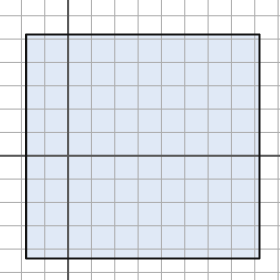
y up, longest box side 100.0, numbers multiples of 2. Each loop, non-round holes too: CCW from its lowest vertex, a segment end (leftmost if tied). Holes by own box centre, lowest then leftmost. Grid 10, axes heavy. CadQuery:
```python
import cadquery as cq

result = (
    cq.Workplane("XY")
    .moveTo(-18.0, -44.0)
    .lineTo(82.0, -44.0)
    .lineTo(82.0, 52.0)
    .lineTo(-18.0, 52.0)
    .close()
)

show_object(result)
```